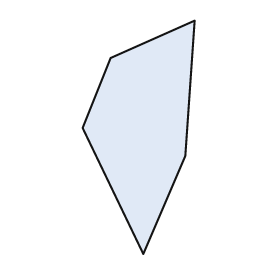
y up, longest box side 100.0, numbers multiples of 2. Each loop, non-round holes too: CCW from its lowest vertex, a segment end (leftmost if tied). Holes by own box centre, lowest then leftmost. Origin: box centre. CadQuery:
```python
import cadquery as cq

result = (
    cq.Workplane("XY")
    .moveTo(2.0, -50.0)
    .lineTo(20.0, -8.0)
    .lineTo(24.0, 50.0)
    .lineTo(-12.0, 34.0)
    .lineTo(-24.0, 4.0)
    .close()
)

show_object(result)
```